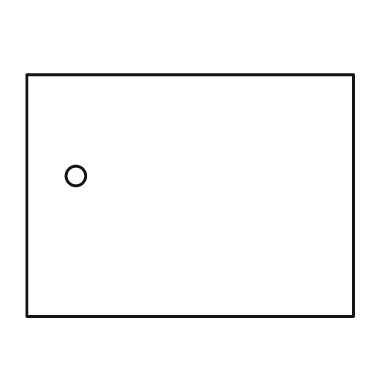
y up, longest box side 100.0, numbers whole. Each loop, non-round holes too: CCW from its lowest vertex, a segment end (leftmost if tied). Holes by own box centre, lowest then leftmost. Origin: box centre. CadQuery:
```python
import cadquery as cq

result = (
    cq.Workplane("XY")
    .moveTo(-50.0, -37.0)
    .lineTo(50.0, -37.0)
    .lineTo(50.0, 37.0)
    .lineTo(-50.0, 37.0)
    .close()
    .moveTo(-35.0, 6.0)
    .circle(3.0)
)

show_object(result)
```